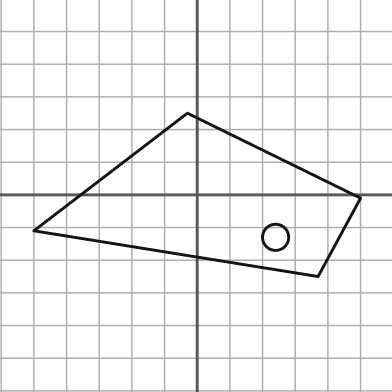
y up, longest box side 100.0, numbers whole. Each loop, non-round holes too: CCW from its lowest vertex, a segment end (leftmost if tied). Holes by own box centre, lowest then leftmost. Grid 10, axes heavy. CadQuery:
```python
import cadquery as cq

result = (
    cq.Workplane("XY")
    .moveTo(37.0, -25.0)
    .lineTo(50.0, -1.0)
    .lineTo(-3.0, 25.0)
    .lineTo(-50.0, -11.0)
    .close()
    .moveTo(24.0, -13.0)
    .circle(4.0)
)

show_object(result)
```